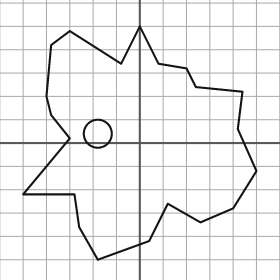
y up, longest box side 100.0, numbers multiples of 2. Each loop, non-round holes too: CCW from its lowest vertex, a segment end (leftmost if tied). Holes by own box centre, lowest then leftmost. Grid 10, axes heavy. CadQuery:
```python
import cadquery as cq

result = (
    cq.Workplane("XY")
    .moveTo(-18.0, -50.0)
    .lineTo(4.0, -42.0)
    .lineTo(12.0, -26.0)
    .lineTo(26.0, -34.0)
    .lineTo(40.0, -28.0)
    .lineTo(50.0, -12.0)
    .lineTo(42.0, 6.0)
    .lineTo(44.0, 22.0)
    .lineTo(24.0, 24.0)
    .lineTo(20.0, 32.0)
    .lineTo(8.0, 34.0)
    .lineTo(0.0, 50.0)
    .lineTo(-8.0, 34.0)
    .lineTo(-30.0, 48.0)
    .lineTo(-38.0, 42.0)
    .lineTo(-40.0, 20.0)
    .lineTo(-38.0, 12.0)
    .lineTo(-30.0, 2.0)
    .lineTo(-50.0, -22.0)
    .lineTo(-28.0, -22.0)
    .lineTo(-26.0, -36.0)
    .close()
    .moveTo(-18.0, 4.0)
    .circle(6.0)
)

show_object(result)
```